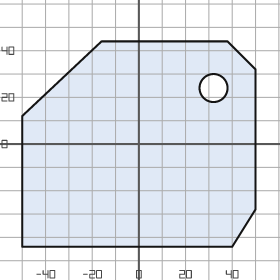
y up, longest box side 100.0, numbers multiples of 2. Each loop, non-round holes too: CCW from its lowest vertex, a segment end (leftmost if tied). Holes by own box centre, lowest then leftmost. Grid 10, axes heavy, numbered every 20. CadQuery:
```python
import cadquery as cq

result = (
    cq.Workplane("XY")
    .moveTo(-50.0, -44.0)
    .lineTo(40.0, -44.0)
    .lineTo(50.0, -28.0)
    .lineTo(50.0, 32.0)
    .lineTo(38.0, 44.0)
    .lineTo(-16.0, 44.0)
    .lineTo(-50.0, 12.0)
    .close()
    .moveTo(32.0, 24.0)
    .circle(6.0)
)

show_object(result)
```